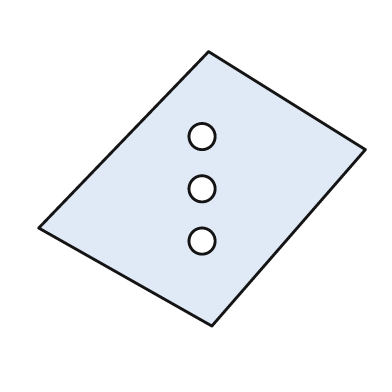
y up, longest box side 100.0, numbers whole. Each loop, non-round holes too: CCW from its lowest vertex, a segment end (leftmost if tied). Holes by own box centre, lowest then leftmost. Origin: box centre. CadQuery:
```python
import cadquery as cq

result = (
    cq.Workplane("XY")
    .moveTo(3.0, -42.0)
    .lineTo(50.0, 12.0)
    .lineTo(2.0, 42.0)
    .lineTo(-50.0, -12.0)
    .close()
    .moveTo(0.0, -16.0)
    .circle(4.0)
    .moveTo(0.0, 0.0)
    .circle(4.0)
    .moveTo(0.0, 16.0)
    .circle(4.0)
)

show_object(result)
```